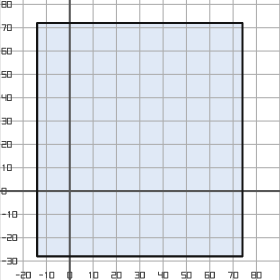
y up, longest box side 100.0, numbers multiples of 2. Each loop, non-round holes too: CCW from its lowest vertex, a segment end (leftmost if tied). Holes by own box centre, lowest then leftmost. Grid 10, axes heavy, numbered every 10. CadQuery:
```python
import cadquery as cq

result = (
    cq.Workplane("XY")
    .moveTo(-14.0, -28.0)
    .lineTo(74.0, -28.0)
    .lineTo(74.0, 72.0)
    .lineTo(-14.0, 72.0)
    .close()
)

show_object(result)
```